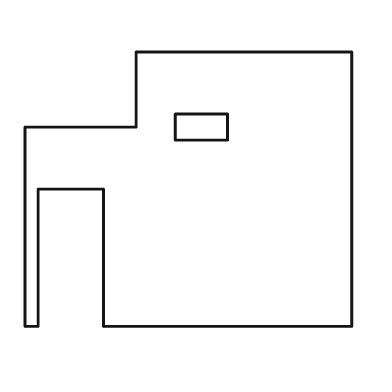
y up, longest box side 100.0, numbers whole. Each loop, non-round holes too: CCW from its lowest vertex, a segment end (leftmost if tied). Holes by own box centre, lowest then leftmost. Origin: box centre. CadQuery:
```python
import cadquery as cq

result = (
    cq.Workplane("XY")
    .moveTo(-50.0, -42.0)
    .lineTo(-46.0, -42.0)
    .lineTo(-46.0, 0.0)
    .lineTo(-26.0, 0.0)
    .lineTo(-26.0, -42.0)
    .lineTo(50.0, -42.0)
    .lineTo(50.0, 42.0)
    .lineTo(-16.0, 42.0)
    .lineTo(-16.0, 19.0)
    .lineTo(-50.0, 19.0)
    .close()
    .moveTo(-4.0, 15.0)
    .lineTo(12.0, 15.0)
    .lineTo(12.0, 23.0)
    .lineTo(-4.0, 23.0)
    .close()
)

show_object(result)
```